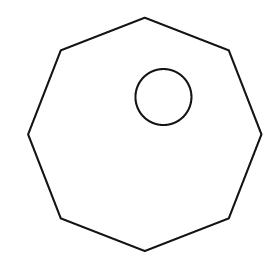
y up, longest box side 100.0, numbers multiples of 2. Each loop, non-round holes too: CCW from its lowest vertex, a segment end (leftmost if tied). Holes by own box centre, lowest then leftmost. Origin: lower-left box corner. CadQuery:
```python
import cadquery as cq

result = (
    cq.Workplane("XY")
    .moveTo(50.0, 0.0)
    .lineTo(86.0, 14.0)
    .lineTo(100.0, 50.0)
    .lineTo(86.0, 86.0)
    .lineTo(50.0, 100.0)
    .lineTo(14.0, 86.0)
    .lineTo(0.0, 50.0)
    .lineTo(14.0, 14.0)
    .close()
    .moveTo(58.0, 66.0)
    .circle(12.0)
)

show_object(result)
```